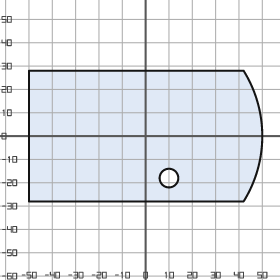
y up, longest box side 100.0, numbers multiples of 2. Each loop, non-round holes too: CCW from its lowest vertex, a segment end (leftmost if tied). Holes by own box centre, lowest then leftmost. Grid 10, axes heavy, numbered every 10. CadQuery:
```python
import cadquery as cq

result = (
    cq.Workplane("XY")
    .moveTo(-50.0, -28.0)
    .lineTo(42.0, -28.0)
    .threePointArc((50.0, 0.0), (42.0, 28.0))
    .lineTo(-50.0, 28.0)
    .close()
    .moveTo(10.0, -18.0)
    .circle(4.0)
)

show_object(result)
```